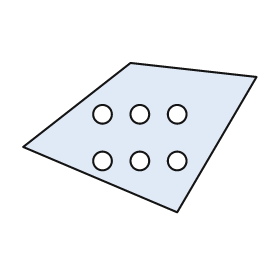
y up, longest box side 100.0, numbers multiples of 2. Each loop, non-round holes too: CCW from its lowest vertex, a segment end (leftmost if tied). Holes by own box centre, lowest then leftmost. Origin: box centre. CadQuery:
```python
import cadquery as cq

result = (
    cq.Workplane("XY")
    .moveTo(16.0, -32.0)
    .lineTo(50.0, 26.0)
    .lineTo(-4.0, 32.0)
    .lineTo(-50.0, -4.0)
    .close()
    .moveTo(-16.0, -10.0)
    .circle(4.0)
    .moveTo(0.0, -10.0)
    .circle(4.0)
    .moveTo(16.0, -10.0)
    .circle(4.0)
    .moveTo(-16.0, 10.0)
    .circle(4.0)
    .moveTo(0.0, 10.0)
    .circle(4.0)
    .moveTo(16.0, 10.0)
    .circle(4.0)
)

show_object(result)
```